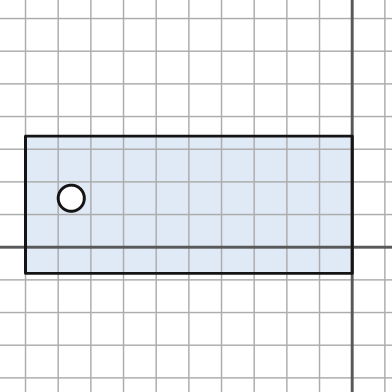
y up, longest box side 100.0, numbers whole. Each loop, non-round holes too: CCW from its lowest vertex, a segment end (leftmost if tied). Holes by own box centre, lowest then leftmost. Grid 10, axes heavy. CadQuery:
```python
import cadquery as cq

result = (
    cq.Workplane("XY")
    .moveTo(-100.0, -8.0)
    .lineTo(0.0, -8.0)
    .lineTo(0.0, 34.0)
    .lineTo(-100.0, 34.0)
    .close()
    .moveTo(-86.0, 15.0)
    .circle(4.0)
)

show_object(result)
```